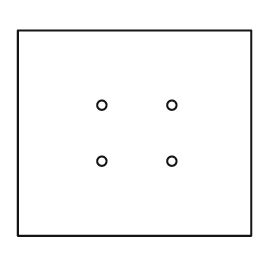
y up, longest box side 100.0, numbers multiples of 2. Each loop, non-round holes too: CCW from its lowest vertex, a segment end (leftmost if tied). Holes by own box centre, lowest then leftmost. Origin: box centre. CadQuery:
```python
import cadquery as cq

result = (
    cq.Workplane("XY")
    .moveTo(-50.0, -44.0)
    .lineTo(50.0, -44.0)
    .lineTo(50.0, 44.0)
    .lineTo(-50.0, 44.0)
    .close()
    .moveTo(-14.0, -12.0)
    .circle(2.0)
    .moveTo(16.0, -12.0)
    .circle(2.0)
    .moveTo(-14.0, 12.0)
    .circle(2.0)
    .moveTo(16.0, 12.0)
    .circle(2.0)
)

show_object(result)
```